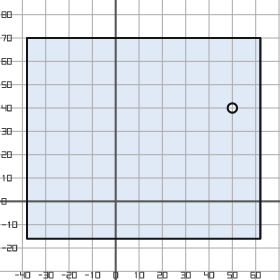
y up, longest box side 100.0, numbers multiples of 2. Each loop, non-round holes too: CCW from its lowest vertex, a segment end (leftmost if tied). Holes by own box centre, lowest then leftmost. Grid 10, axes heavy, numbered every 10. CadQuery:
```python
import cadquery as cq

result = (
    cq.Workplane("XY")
    .moveTo(-38.0, -16.0)
    .lineTo(62.0, -16.0)
    .lineTo(62.0, 70.0)
    .lineTo(-38.0, 70.0)
    .close()
    .moveTo(50.0, 40.0)
    .circle(2.0)
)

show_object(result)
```